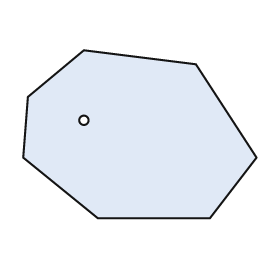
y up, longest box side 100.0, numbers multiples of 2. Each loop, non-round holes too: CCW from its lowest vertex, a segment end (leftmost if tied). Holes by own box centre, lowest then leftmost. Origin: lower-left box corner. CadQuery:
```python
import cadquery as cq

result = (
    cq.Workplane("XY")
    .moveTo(32.0, 0.0)
    .lineTo(80.0, 0.0)
    .lineTo(100.0, 26.0)
    .lineTo(74.0, 66.0)
    .lineTo(26.0, 72.0)
    .lineTo(2.0, 52.0)
    .lineTo(0.0, 26.0)
    .close()
    .moveTo(26.0, 42.0)
    .circle(2.0)
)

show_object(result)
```